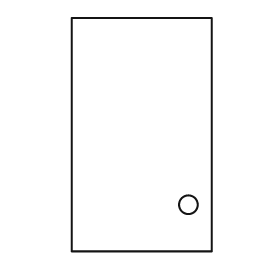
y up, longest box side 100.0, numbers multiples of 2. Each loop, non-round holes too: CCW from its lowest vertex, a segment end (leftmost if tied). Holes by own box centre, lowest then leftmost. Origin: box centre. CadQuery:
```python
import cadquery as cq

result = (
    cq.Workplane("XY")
    .moveTo(-30.0, -50.0)
    .lineTo(30.0, -50.0)
    .lineTo(30.0, 50.0)
    .lineTo(-30.0, 50.0)
    .close()
    .moveTo(20.0, -30.0)
    .circle(4.0)
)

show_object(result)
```